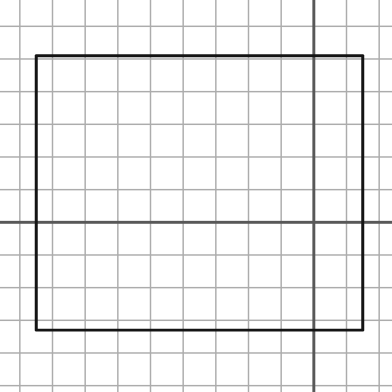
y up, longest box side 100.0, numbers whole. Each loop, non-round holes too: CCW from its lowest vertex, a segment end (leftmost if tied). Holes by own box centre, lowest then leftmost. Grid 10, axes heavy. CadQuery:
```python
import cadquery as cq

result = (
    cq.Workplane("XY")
    .moveTo(-85.0, -33.0)
    .lineTo(15.0, -33.0)
    .lineTo(15.0, 51.0)
    .lineTo(-85.0, 51.0)
    .close()
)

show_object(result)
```